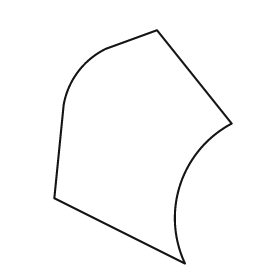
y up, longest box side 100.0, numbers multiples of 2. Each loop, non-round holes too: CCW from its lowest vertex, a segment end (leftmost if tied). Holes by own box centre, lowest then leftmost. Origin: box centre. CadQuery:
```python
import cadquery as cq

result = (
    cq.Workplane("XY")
    .moveTo(18.0, -50.0)
    .threePointArc((16.0, -16.0), (38.0, 10.0))
    .lineTo(6.0, 50.0)
    .lineTo(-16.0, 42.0)
    .threePointArc((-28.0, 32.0), (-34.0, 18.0))
    .lineTo(-38.0, -22.0)
    .close()
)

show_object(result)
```